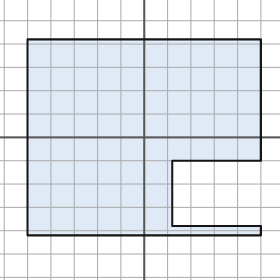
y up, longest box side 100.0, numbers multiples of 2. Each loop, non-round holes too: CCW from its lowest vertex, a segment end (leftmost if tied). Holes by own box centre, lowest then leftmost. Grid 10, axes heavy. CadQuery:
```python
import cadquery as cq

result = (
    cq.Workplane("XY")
    .moveTo(-50.0, -42.0)
    .lineTo(50.0, -42.0)
    .lineTo(50.0, -38.0)
    .lineTo(12.0, -38.0)
    .lineTo(12.0, -10.0)
    .lineTo(50.0, -10.0)
    .lineTo(50.0, 42.0)
    .lineTo(-50.0, 42.0)
    .close()
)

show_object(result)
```